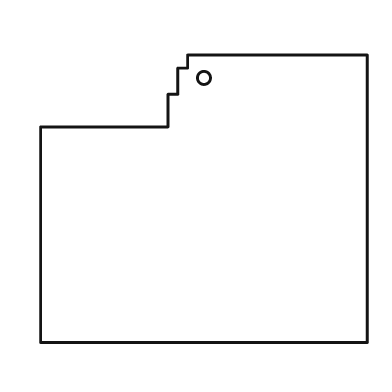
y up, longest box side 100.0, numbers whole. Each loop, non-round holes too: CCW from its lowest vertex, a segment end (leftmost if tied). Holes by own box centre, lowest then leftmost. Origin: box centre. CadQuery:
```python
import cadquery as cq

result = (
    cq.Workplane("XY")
    .moveTo(-50.0, -44.0)
    .lineTo(50.0, -44.0)
    .lineTo(50.0, 44.0)
    .lineTo(-5.0, 44.0)
    .lineTo(-5.0, 40.0)
    .lineTo(-8.0, 40.0)
    .lineTo(-8.0, 32.0)
    .lineTo(-11.0, 32.0)
    .lineTo(-11.0, 22.0)
    .lineTo(-50.0, 22.0)
    .close()
    .moveTo(0.0, 37.0)
    .circle(2.0)
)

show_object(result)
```